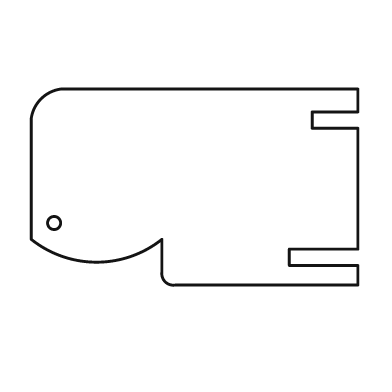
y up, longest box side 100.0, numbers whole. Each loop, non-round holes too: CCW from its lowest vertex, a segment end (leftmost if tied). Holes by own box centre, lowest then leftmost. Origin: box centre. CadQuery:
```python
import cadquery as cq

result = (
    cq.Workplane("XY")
    .moveTo(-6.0, -30.0)
    .lineTo(50.0, -30.0)
    .lineTo(50.0, -24.0)
    .lineTo(29.0, -24.0)
    .lineTo(29.0, -19.0)
    .lineTo(50.0, -19.0)
    .lineTo(50.0, 18.0)
    .lineTo(36.0, 18.0)
    .lineTo(36.0, 23.0)
    .lineTo(50.0, 23.0)
    .lineTo(50.0, 30.0)
    .lineTo(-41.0, 30.0)
    .threePointArc((-47.0, 27.0), (-50.0, 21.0))
    .lineTo(-50.0, -16.0)
    .threePointArc((-30.0, -23.0), (-10.0, -16.0))
    .lineTo(-10.0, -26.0)
    .threePointArc((-9.0, -29.0), (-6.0, -30.0))
    .close()
    .moveTo(-43.0, -11.0)
    .circle(2.0)
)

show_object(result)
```